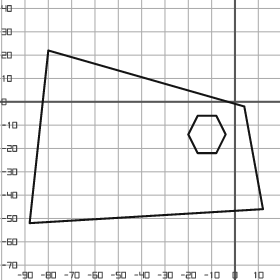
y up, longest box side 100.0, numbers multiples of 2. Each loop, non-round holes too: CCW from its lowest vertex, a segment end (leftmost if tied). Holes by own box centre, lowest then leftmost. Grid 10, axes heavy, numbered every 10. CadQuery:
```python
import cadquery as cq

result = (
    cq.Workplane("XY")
    .moveTo(-88.0, -52.0)
    .lineTo(12.0, -46.0)
    .lineTo(4.0, -2.0)
    .lineTo(-80.0, 22.0)
    .close()
    .moveTo(-16.0, -22.0)
    .lineTo(-8.0, -22.0)
    .lineTo(-4.0, -14.0)
    .lineTo(-8.0, -6.0)
    .lineTo(-16.0, -6.0)
    .lineTo(-20.0, -14.0)
    .close()
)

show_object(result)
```